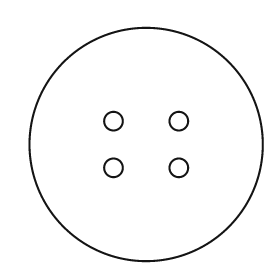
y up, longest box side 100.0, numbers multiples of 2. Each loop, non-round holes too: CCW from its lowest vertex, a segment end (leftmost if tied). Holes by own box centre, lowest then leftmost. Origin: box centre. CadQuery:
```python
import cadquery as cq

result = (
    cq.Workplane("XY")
    .moveTo(0.0, 0.0)
    .circle(50.0)
    .moveTo(-14.0, -10.0)
    .circle(4.0)
    .moveTo(14.0, -10.0)
    .circle(4.0)
    .moveTo(-14.0, 10.0)
    .circle(4.0)
    .moveTo(14.0, 10.0)
    .circle(4.0)
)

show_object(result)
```